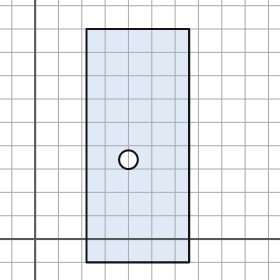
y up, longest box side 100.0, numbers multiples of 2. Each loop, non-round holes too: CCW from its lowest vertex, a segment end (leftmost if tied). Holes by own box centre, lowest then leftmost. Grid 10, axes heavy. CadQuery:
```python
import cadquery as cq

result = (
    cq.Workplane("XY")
    .moveTo(22.0, -10.0)
    .lineTo(66.0, -10.0)
    .lineTo(66.0, 90.0)
    .lineTo(22.0, 90.0)
    .close()
    .moveTo(40.0, 34.0)
    .circle(4.0)
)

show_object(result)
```